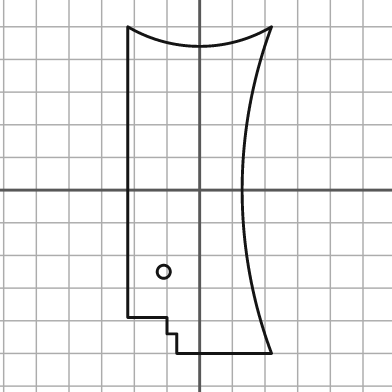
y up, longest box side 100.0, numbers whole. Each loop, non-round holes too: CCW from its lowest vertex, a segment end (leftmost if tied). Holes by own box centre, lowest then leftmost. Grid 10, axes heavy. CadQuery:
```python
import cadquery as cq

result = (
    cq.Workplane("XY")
    .moveTo(-7.0, -50.0)
    .lineTo(22.0, -50.0)
    .threePointArc((13.0, 0.0), (22.0, 50.0))
    .threePointArc((0.0, 44.0), (-22.0, 50.0))
    .lineTo(-22.0, -39.0)
    .lineTo(-10.0, -39.0)
    .lineTo(-10.0, -44.0)
    .lineTo(-7.0, -44.0)
    .close()
    .moveTo(-11.0, -25.0)
    .circle(2.0)
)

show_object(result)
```